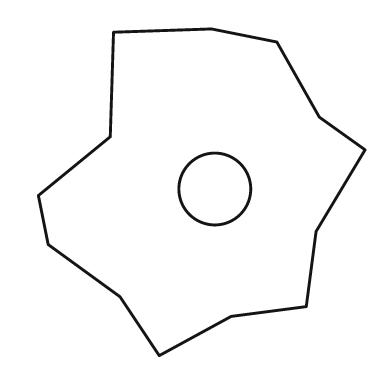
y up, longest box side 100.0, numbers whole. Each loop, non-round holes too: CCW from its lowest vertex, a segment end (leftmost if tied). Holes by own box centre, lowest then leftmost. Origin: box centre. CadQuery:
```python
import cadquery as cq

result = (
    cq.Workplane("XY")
    .moveTo(-13.0, -50.0)
    .lineTo(9.0, -38.0)
    .lineTo(32.0, -35.0)
    .lineTo(35.0, -12.0)
    .lineTo(50.0, 13.0)
    .lineTo(36.0, 23.0)
    .lineTo(23.0, 46.0)
    .lineTo(3.0, 50.0)
    .lineTo(-27.0, 49.0)
    .lineTo(-28.0, 17.0)
    .lineTo(-50.0, -1.0)
    .lineTo(-47.0, -16.0)
    .lineTo(-25.0, -32.0)
    .close()
    .moveTo(4.0, 1.0)
    .circle(11.0)
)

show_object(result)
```